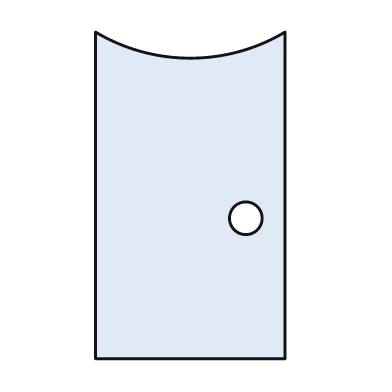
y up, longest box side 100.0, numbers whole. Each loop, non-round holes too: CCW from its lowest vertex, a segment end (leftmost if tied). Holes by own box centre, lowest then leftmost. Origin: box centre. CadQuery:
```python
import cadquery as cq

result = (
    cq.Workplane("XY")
    .moveTo(-29.0, -50.0)
    .lineTo(29.0, -50.0)
    .lineTo(29.0, 50.0)
    .threePointArc((0.0, 42.0), (-29.0, 50.0))
    .close()
    .moveTo(17.0, -7.0)
    .circle(5.0)
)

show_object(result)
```